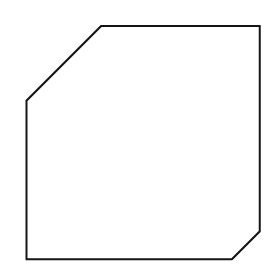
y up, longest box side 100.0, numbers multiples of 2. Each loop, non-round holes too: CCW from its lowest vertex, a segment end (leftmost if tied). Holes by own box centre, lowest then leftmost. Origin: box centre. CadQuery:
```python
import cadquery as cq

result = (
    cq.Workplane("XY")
    .moveTo(-50.0, -50.0)
    .lineTo(38.0, -50.0)
    .lineTo(50.0, -38.0)
    .lineTo(50.0, 50.0)
    .lineTo(-18.0, 50.0)
    .lineTo(-50.0, 18.0)
    .close()
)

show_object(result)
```